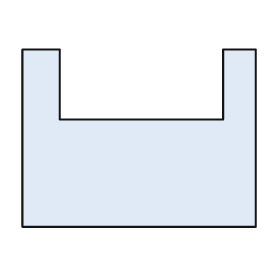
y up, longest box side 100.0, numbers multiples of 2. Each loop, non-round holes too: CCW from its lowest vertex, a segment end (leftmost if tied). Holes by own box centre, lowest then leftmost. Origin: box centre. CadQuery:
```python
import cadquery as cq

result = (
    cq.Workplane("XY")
    .moveTo(-50.0, -38.0)
    .lineTo(50.0, -38.0)
    .lineTo(50.0, 38.0)
    .lineTo(36.0, 38.0)
    .lineTo(36.0, 8.0)
    .lineTo(-34.0, 8.0)
    .lineTo(-34.0, 38.0)
    .lineTo(-50.0, 38.0)
    .close()
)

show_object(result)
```